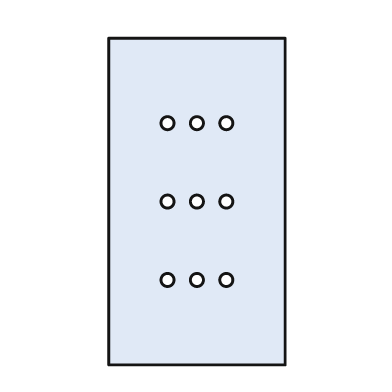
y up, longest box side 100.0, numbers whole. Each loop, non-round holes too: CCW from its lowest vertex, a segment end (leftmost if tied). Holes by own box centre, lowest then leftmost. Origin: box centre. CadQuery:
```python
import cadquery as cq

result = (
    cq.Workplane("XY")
    .moveTo(-27.0, -50.0)
    .lineTo(27.0, -50.0)
    .lineTo(27.0, 50.0)
    .lineTo(-27.0, 50.0)
    .close()
    .moveTo(-9.0, -24.0)
    .circle(2.0)
    .moveTo(0.0, -24.0)
    .circle(2.0)
    .moveTo(9.0, -24.0)
    .circle(2.0)
    .moveTo(-9.0, 0.0)
    .circle(2.0)
    .moveTo(0.0, 0.0)
    .circle(2.0)
    .moveTo(9.0, 0.0)
    .circle(2.0)
    .moveTo(-9.0, 24.0)
    .circle(2.0)
    .moveTo(0.0, 24.0)
    .circle(2.0)
    .moveTo(9.0, 24.0)
    .circle(2.0)
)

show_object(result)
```